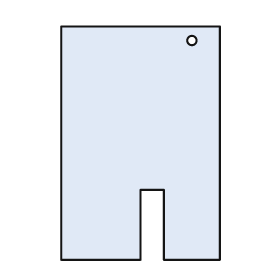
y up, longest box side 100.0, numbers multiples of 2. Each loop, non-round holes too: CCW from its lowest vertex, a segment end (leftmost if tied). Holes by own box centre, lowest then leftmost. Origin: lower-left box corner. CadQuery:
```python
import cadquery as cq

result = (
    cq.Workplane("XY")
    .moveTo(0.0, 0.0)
    .lineTo(34.0, 0.0)
    .lineTo(34.0, 30.0)
    .lineTo(44.0, 30.0)
    .lineTo(44.0, 0.0)
    .lineTo(68.0, 0.0)
    .lineTo(68.0, 100.0)
    .lineTo(0.0, 100.0)
    .close()
    .moveTo(56.0, 94.0)
    .circle(2.0)
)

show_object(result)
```